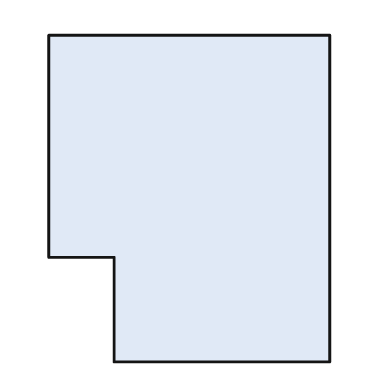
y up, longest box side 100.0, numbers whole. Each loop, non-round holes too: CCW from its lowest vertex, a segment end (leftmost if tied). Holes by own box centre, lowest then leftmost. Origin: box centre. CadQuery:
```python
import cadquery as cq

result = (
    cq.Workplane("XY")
    .moveTo(-23.0, -50.0)
    .lineTo(43.0, -50.0)
    .lineTo(43.0, 50.0)
    .lineTo(-43.0, 50.0)
    .lineTo(-43.0, -18.0)
    .lineTo(-23.0, -18.0)
    .close()
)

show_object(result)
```